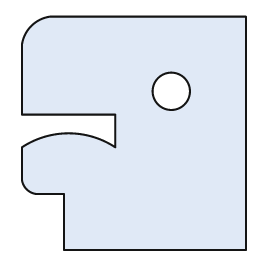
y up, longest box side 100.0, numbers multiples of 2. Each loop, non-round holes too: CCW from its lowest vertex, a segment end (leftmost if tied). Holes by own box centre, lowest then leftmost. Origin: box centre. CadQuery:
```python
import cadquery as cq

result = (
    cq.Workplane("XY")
    .moveTo(-30.0, -50.0)
    .lineTo(48.0, -50.0)
    .lineTo(48.0, 50.0)
    .lineTo(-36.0, 50.0)
    .threePointArc((-44.0, 46.0), (-48.0, 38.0))
    .lineTo(-48.0, 8.0)
    .lineTo(-8.0, 8.0)
    .lineTo(-8.0, -6.0)
    .threePointArc((-28.0, 0.0), (-48.0, -6.0))
    .lineTo(-48.0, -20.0)
    .threePointArc((-46.0, -24.0), (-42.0, -26.0))
    .lineTo(-30.0, -26.0)
    .close()
    .moveTo(16.0, 18.0)
    .circle(8.0)
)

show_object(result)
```